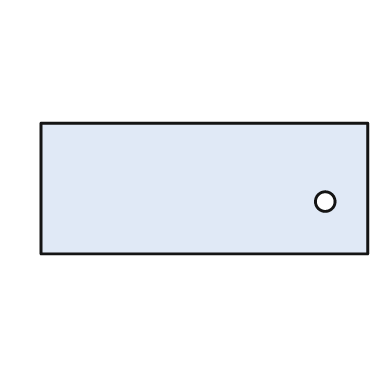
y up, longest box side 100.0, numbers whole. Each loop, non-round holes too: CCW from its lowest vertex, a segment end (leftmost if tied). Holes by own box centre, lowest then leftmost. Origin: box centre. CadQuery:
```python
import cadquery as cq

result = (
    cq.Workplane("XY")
    .moveTo(-50.0, -20.0)
    .lineTo(50.0, -20.0)
    .lineTo(50.0, 20.0)
    .lineTo(-50.0, 20.0)
    .close()
    .moveTo(37.0, -4.0)
    .circle(3.0)
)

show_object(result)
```